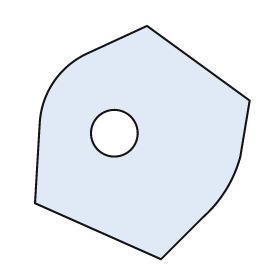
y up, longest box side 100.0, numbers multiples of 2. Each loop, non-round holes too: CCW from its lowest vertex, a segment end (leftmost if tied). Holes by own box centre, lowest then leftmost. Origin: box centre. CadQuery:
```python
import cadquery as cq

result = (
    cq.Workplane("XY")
    .moveTo(8.0, -50.0)
    .lineTo(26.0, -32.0)
    .threePointArc((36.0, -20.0), (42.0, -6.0))
    .lineTo(46.0, 18.0)
    .lineTo(2.0, 50.0)
    .lineTo(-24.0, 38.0)
    .threePointArc((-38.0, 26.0), (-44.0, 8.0))
    .lineTo(-46.0, -26.0)
    .close()
    .moveTo(-12.0, 4.0)
    .circle(10.0)
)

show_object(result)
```